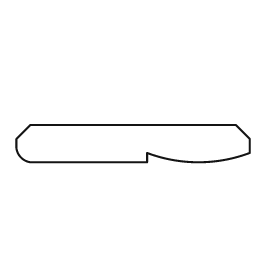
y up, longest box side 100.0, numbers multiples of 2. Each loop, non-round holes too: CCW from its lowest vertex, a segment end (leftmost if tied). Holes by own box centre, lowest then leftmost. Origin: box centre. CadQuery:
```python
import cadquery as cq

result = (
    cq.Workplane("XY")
    .moveTo(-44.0, -8.0)
    .lineTo(6.0, -8.0)
    .lineTo(6.0, -4.0)
    .threePointArc((28.0, -8.0), (50.0, -4.0))
    .lineTo(50.0, 2.0)
    .lineTo(44.0, 8.0)
    .lineTo(-44.0, 8.0)
    .lineTo(-50.0, 2.0)
    .lineTo(-50.0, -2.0)
    .threePointArc((-48.0, -6.0), (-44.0, -8.0))
    .close()
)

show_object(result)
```